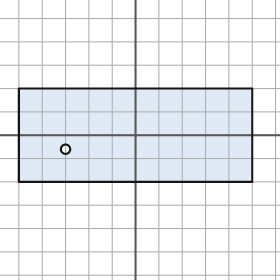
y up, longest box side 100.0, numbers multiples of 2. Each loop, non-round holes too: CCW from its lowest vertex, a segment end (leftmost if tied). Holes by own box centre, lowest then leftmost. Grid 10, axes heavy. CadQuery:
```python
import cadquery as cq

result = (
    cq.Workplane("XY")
    .moveTo(-50.0, -20.0)
    .lineTo(50.0, -20.0)
    .lineTo(50.0, 20.0)
    .lineTo(-50.0, 20.0)
    .close()
    .moveTo(-30.0, -6.0)
    .circle(2.0)
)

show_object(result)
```